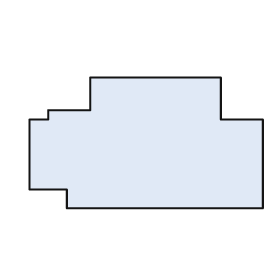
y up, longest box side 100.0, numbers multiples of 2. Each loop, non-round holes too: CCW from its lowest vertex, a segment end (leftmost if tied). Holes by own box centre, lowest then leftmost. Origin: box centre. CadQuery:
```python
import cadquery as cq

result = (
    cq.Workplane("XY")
    .moveTo(-34.0, -28.0)
    .lineTo(50.0, -28.0)
    .lineTo(50.0, 10.0)
    .lineTo(32.0, 10.0)
    .lineTo(32.0, 28.0)
    .lineTo(-24.0, 28.0)
    .lineTo(-24.0, 14.0)
    .lineTo(-42.0, 14.0)
    .lineTo(-42.0, 10.0)
    .lineTo(-50.0, 10.0)
    .lineTo(-50.0, -20.0)
    .lineTo(-34.0, -20.0)
    .close()
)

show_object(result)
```